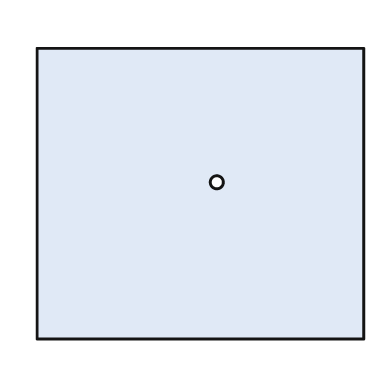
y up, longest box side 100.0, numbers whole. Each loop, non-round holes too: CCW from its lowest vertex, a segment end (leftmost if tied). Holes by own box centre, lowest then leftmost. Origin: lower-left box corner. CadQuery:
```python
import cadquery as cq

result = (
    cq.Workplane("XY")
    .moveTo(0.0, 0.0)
    .lineTo(100.0, 0.0)
    .lineTo(100.0, 89.0)
    .lineTo(0.0, 89.0)
    .close()
    .moveTo(55.0, 48.0)
    .circle(2.0)
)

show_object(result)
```